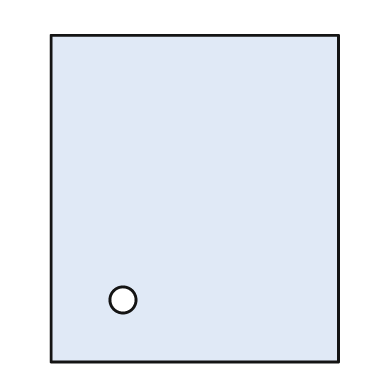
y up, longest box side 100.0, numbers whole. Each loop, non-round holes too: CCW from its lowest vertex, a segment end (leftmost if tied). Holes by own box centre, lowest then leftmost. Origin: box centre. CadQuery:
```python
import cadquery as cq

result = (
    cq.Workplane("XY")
    .moveTo(-44.0, -50.0)
    .lineTo(44.0, -50.0)
    .lineTo(44.0, 50.0)
    .lineTo(-44.0, 50.0)
    .close()
    .moveTo(-22.0, -31.0)
    .circle(4.0)
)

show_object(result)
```